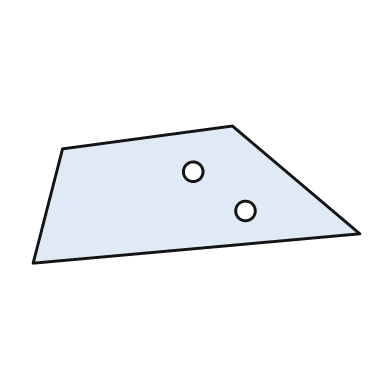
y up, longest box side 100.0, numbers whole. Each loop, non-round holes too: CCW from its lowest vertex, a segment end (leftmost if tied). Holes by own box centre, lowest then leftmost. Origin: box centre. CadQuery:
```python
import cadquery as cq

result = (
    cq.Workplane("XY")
    .moveTo(-50.0, -21.0)
    .lineTo(50.0, -12.0)
    .lineTo(11.0, 21.0)
    .lineTo(-41.0, 14.0)
    .close()
    .moveTo(15.0, -5.0)
    .circle(3.0)
    .moveTo(-1.0, 7.0)
    .circle(3.0)
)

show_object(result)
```